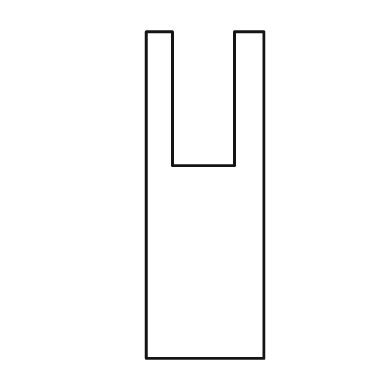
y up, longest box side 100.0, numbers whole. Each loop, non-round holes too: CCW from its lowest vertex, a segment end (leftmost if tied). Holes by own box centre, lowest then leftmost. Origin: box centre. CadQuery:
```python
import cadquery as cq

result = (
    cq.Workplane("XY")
    .moveTo(-18.0, -50.0)
    .lineTo(18.0, -50.0)
    .lineTo(18.0, 50.0)
    .lineTo(9.0, 50.0)
    .lineTo(9.0, 9.0)
    .lineTo(-10.0, 9.0)
    .lineTo(-10.0, 50.0)
    .lineTo(-18.0, 50.0)
    .close()
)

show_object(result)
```